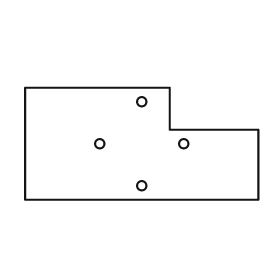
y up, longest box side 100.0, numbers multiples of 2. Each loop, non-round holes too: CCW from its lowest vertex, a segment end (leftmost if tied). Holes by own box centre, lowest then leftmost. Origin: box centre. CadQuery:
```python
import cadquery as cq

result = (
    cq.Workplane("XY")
    .moveTo(-50.0, -24.0)
    .lineTo(50.0, -24.0)
    .lineTo(50.0, 6.0)
    .lineTo(12.0, 6.0)
    .lineTo(12.0, 24.0)
    .lineTo(-50.0, 24.0)
    .close()
    .moveTo(0.0, -18.0)
    .circle(2.0)
    .moveTo(-18.0, 0.0)
    .circle(2.0)
    .moveTo(18.0, 0.0)
    .circle(2.0)
    .moveTo(0.0, 18.0)
    .circle(2.0)
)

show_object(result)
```